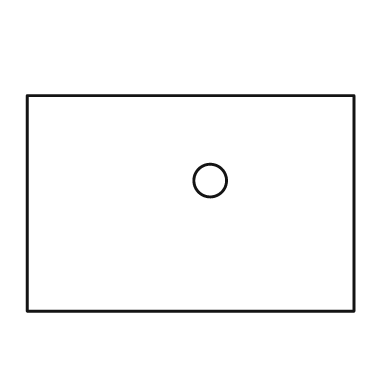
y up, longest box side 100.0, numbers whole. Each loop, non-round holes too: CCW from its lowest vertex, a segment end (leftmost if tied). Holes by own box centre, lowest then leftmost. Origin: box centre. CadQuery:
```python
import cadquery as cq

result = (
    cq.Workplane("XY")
    .moveTo(-50.0, -33.0)
    .lineTo(50.0, -33.0)
    .lineTo(50.0, 33.0)
    .lineTo(-50.0, 33.0)
    .close()
    .moveTo(6.0, 7.0)
    .circle(5.0)
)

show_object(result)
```